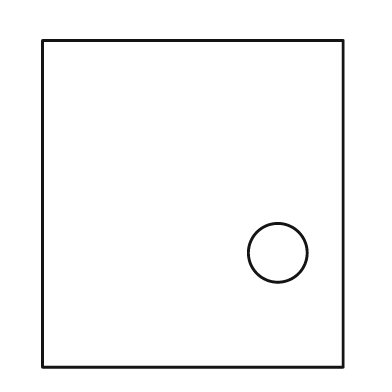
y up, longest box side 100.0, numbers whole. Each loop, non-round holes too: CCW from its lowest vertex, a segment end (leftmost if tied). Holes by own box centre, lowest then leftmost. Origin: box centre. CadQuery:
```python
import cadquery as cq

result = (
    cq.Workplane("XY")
    .moveTo(-46.0, -50.0)
    .lineTo(46.0, -50.0)
    .lineTo(46.0, 50.0)
    .lineTo(-46.0, 50.0)
    .close()
    .moveTo(26.0, -15.0)
    .circle(9.0)
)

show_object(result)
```